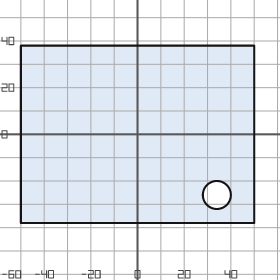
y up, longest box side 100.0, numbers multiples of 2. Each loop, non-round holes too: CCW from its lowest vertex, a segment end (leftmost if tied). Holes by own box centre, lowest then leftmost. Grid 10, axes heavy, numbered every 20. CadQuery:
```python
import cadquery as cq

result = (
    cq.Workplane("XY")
    .moveTo(-50.0, -38.0)
    .lineTo(50.0, -38.0)
    .lineTo(50.0, 38.0)
    .lineTo(-50.0, 38.0)
    .close()
    .moveTo(34.0, -26.0)
    .circle(6.0)
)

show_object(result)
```